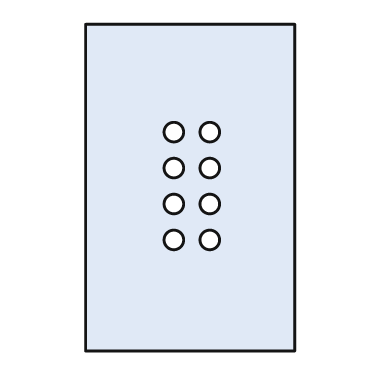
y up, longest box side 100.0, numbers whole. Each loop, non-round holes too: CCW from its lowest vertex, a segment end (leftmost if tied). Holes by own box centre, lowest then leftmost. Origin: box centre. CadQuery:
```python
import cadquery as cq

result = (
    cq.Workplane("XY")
    .moveTo(-32.0, -50.0)
    .lineTo(32.0, -50.0)
    .lineTo(32.0, 50.0)
    .lineTo(-32.0, 50.0)
    .close()
    .moveTo(-5.0, -16.0)
    .circle(3.0)
    .moveTo(6.0, -16.0)
    .circle(3.0)
    .moveTo(-5.0, -5.0)
    .circle(3.0)
    .moveTo(6.0, -5.0)
    .circle(3.0)
    .moveTo(-5.0, 6.0)
    .circle(3.0)
    .moveTo(6.0, 6.0)
    .circle(3.0)
    .moveTo(-5.0, 17.0)
    .circle(3.0)
    .moveTo(6.0, 17.0)
    .circle(3.0)
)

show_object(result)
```